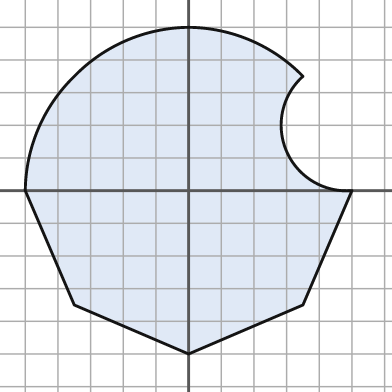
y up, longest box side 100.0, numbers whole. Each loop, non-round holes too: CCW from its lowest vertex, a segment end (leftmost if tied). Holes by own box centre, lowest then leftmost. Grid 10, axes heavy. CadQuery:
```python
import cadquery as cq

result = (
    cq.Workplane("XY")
    .moveTo(0.0, -50.0)
    .lineTo(35.0, -35.0)
    .lineTo(50.0, 0.0)
    .threePointArc((30.0, 12.0), (35.0, 35.0))
    .threePointArc((19.0, 46.0), (0.0, 50.0))
    .threePointArc((-19.0, 46.0), (-35.0, 35.0))
    .threePointArc((-46.0, 19.0), (-50.0, 0.0))
    .lineTo(-35.0, -35.0)
    .close()
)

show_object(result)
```